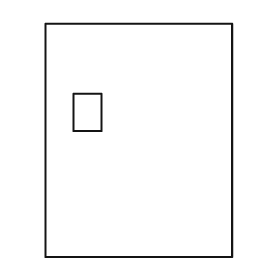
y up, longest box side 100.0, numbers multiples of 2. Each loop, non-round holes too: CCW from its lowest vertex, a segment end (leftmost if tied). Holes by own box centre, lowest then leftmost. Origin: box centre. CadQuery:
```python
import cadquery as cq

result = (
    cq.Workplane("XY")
    .moveTo(-40.0, -50.0)
    .lineTo(40.0, -50.0)
    .lineTo(40.0, 50.0)
    .lineTo(-40.0, 50.0)
    .close()
    .moveTo(-28.0, 4.0)
    .lineTo(-16.0, 4.0)
    .lineTo(-16.0, 20.0)
    .lineTo(-28.0, 20.0)
    .close()
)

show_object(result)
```